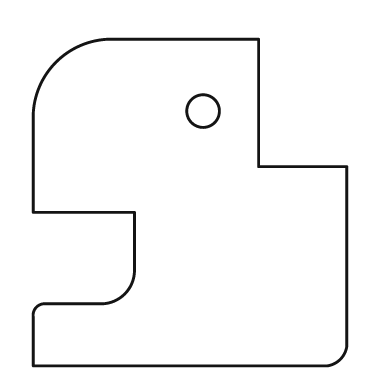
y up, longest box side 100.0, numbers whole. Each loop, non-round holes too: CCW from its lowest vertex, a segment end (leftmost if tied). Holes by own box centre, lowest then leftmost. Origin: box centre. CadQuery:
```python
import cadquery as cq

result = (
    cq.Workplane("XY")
    .moveTo(-48.0, -50.0)
    .lineTo(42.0, -50.0)
    .threePointArc((46.0, -48.0), (48.0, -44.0))
    .lineTo(48.0, 11.0)
    .lineTo(21.0, 11.0)
    .lineTo(21.0, 50.0)
    .lineTo(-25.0, 50.0)
    .threePointArc((-41.0, 43.0), (-48.0, 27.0))
    .lineTo(-48.0, -3.0)
    .lineTo(-17.0, -3.0)
    .lineTo(-17.0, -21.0)
    .threePointArc((-20.0, -28.0), (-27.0, -31.0))
    .lineTo(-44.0, -31.0)
    .threePointArc((-47.0, -32.0), (-48.0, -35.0))
    .close()
    .moveTo(4.0, 28.0)
    .circle(5.0)
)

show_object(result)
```